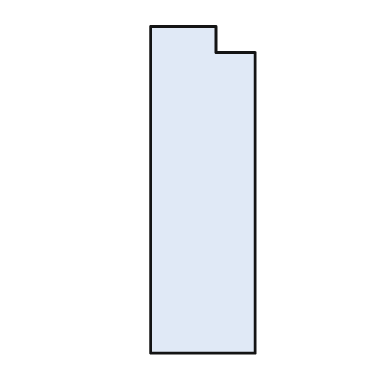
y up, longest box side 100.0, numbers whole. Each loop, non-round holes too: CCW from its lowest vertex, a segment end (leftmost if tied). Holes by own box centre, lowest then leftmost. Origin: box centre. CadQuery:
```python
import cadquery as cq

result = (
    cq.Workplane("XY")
    .moveTo(-16.0, -50.0)
    .lineTo(16.0, -50.0)
    .lineTo(16.0, 42.0)
    .lineTo(4.0, 42.0)
    .lineTo(4.0, 50.0)
    .lineTo(-16.0, 50.0)
    .close()
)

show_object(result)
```